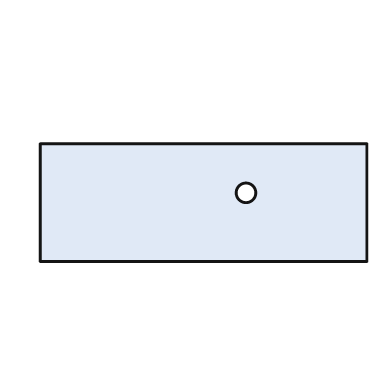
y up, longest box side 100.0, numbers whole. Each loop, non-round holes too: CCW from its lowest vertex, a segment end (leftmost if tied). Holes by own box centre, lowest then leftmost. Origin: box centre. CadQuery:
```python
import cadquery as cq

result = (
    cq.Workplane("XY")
    .moveTo(-50.0, -18.0)
    .lineTo(50.0, -18.0)
    .lineTo(50.0, 18.0)
    .lineTo(-50.0, 18.0)
    .close()
    .moveTo(13.0, 3.0)
    .circle(3.0)
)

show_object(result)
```